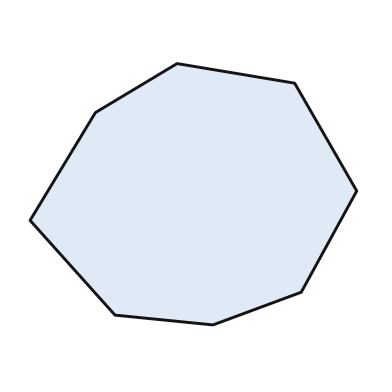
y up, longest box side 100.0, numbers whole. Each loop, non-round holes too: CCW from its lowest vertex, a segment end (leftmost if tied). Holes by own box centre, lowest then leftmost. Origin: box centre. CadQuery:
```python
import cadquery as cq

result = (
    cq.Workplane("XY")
    .moveTo(6.0, -40.0)
    .lineTo(33.0, -30.0)
    .lineTo(50.0, 1.0)
    .lineTo(31.0, 34.0)
    .lineTo(-5.0, 40.0)
    .lineTo(-30.0, 25.0)
    .lineTo(-50.0, -8.0)
    .lineTo(-24.0, -37.0)
    .close()
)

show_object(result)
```